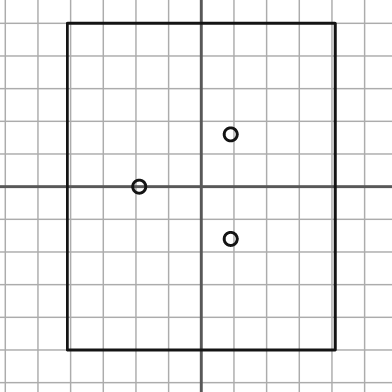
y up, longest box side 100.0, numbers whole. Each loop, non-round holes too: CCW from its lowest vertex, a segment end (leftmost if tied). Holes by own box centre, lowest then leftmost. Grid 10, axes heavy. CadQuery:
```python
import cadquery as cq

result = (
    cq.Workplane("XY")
    .moveTo(-41.0, -50.0)
    .lineTo(41.0, -50.0)
    .lineTo(41.0, 50.0)
    .lineTo(-41.0, 50.0)
    .close()
    .moveTo(9.0, -16.0)
    .circle(2.0)
    .moveTo(-19.0, 0.0)
    .circle(2.0)
    .moveTo(9.0, 16.0)
    .circle(2.0)
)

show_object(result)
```